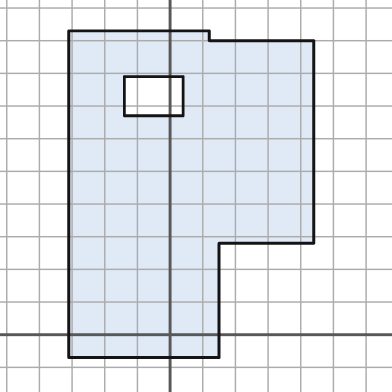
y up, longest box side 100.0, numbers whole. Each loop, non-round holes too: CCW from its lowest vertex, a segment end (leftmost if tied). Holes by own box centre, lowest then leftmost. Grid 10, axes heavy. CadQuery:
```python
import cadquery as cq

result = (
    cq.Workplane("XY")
    .moveTo(-31.0, -7.0)
    .lineTo(15.0, -7.0)
    .lineTo(15.0, 28.0)
    .lineTo(44.0, 28.0)
    .lineTo(44.0, 90.0)
    .lineTo(12.0, 90.0)
    .lineTo(12.0, 93.0)
    .lineTo(-31.0, 93.0)
    .close()
    .moveTo(-14.0, 67.0)
    .lineTo(4.0, 67.0)
    .lineTo(4.0, 79.0)
    .lineTo(-14.0, 79.0)
    .close()
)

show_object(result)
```